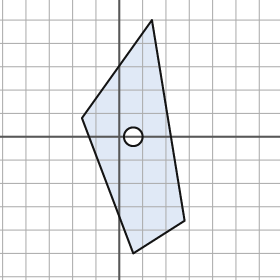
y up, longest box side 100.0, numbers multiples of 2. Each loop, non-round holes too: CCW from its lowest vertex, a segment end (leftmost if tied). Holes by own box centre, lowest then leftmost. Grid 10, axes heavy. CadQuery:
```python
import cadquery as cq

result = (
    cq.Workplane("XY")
    .moveTo(6.0, -50.0)
    .lineTo(28.0, -36.0)
    .lineTo(14.0, 50.0)
    .lineTo(-16.0, 8.0)
    .close()
    .moveTo(6.0, 0.0)
    .circle(4.0)
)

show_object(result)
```